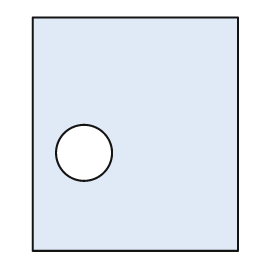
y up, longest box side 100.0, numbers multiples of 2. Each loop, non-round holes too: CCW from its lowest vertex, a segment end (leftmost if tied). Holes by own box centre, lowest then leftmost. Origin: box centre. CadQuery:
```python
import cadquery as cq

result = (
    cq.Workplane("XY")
    .moveTo(-44.0, -50.0)
    .lineTo(44.0, -50.0)
    .lineTo(44.0, 50.0)
    .lineTo(-44.0, 50.0)
    .close()
    .moveTo(-22.0, -8.0)
    .circle(12.0)
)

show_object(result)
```